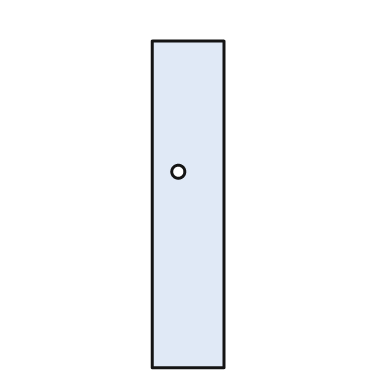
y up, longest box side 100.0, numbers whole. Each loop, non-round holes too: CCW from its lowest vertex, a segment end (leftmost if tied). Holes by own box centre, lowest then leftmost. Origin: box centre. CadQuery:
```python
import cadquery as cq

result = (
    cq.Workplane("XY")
    .moveTo(-11.0, -50.0)
    .lineTo(11.0, -50.0)
    .lineTo(11.0, 50.0)
    .lineTo(-11.0, 50.0)
    .close()
    .moveTo(-3.0, 10.0)
    .circle(2.0)
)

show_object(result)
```